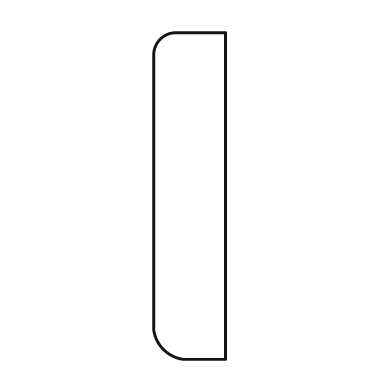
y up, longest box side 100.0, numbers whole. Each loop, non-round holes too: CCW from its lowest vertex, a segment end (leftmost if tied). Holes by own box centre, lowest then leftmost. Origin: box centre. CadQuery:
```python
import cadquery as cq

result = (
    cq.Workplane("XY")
    .moveTo(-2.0, -50.0)
    .lineTo(11.0, -50.0)
    .lineTo(11.0, 50.0)
    .lineTo(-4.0, 50.0)
    .threePointArc((-9.0, 48.0), (-11.0, 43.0))
    .lineTo(-11.0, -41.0)
    .threePointArc((-8.0, -47.0), (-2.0, -50.0))
    .close()
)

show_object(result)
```